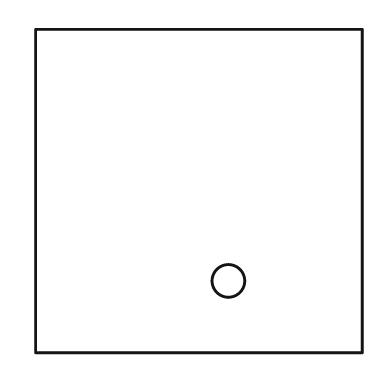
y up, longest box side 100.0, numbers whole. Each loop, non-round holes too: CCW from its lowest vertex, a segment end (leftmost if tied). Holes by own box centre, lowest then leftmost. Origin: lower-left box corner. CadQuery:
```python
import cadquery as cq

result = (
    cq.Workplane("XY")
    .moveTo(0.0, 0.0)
    .lineTo(100.0, 0.0)
    .lineTo(100.0, 99.0)
    .lineTo(0.0, 99.0)
    .close()
    .moveTo(59.0, 22.0)
    .circle(5.0)
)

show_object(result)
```